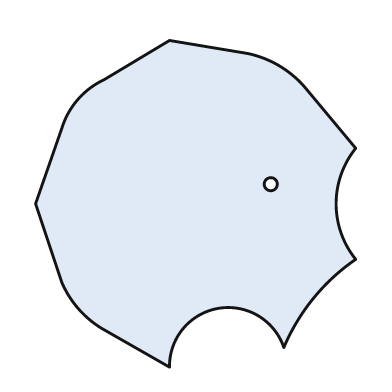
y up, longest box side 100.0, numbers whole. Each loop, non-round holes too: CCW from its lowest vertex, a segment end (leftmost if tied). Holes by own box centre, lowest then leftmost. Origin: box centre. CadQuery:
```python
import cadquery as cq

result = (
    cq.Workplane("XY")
    .moveTo(-8.0, -50.0)
    .threePointArc((7.0, -32.0), (27.0, -44.0))
    .threePointArc((36.0, -29.0), (49.0, -17.0))
    .threePointArc((43.0, 0.0), (49.0, 17.0))
    .lineTo(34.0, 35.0)
    .threePointArc((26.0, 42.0), (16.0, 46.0))
    .lineTo(-8.0, 50.0)
    .lineTo(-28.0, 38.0)
    .threePointArc((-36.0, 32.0), (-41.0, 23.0))
    .lineTo(-49.0, 0.0)
    .lineTo(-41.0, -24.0)
    .threePointArc((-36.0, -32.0), (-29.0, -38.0))
    .close()
    .moveTo(23.0, 6.0)
    .circle(2.0)
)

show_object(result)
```